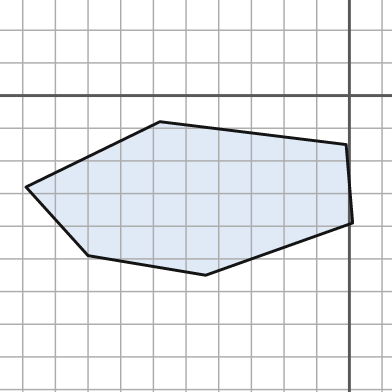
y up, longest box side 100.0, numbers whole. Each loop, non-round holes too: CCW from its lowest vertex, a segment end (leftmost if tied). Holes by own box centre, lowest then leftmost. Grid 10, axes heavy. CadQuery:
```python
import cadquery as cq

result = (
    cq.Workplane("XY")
    .moveTo(-44.0, -55.0)
    .lineTo(1.0, -39.0)
    .lineTo(-1.0, -15.0)
    .lineTo(-58.0, -8.0)
    .lineTo(-99.0, -28.0)
    .lineTo(-80.0, -49.0)
    .close()
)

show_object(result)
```